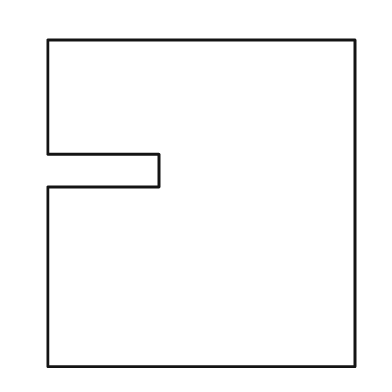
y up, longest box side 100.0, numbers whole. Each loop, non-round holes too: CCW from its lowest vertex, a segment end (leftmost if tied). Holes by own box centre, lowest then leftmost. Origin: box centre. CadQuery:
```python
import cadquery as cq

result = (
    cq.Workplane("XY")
    .moveTo(-47.0, -50.0)
    .lineTo(47.0, -50.0)
    .lineTo(47.0, 50.0)
    .lineTo(-47.0, 50.0)
    .lineTo(-47.0, 15.0)
    .lineTo(-13.0, 15.0)
    .lineTo(-13.0, 5.0)
    .lineTo(-47.0, 5.0)
    .close()
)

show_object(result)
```